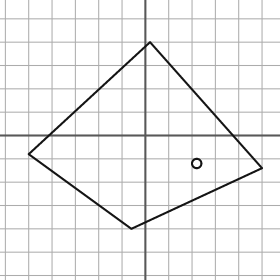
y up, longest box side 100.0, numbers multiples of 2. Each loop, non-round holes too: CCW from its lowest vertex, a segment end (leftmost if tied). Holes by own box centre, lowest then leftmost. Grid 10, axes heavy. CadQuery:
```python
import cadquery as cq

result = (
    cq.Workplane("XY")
    .moveTo(-6.0, -40.0)
    .lineTo(50.0, -14.0)
    .lineTo(2.0, 40.0)
    .lineTo(-50.0, -8.0)
    .close()
    .moveTo(22.0, -12.0)
    .circle(2.0)
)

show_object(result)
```